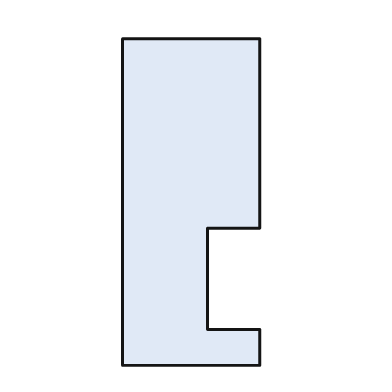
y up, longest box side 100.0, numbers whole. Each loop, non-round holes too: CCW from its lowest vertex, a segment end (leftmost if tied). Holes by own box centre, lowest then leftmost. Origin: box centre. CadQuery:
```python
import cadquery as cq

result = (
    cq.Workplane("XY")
    .moveTo(-21.0, -50.0)
    .lineTo(21.0, -50.0)
    .lineTo(21.0, -39.0)
    .lineTo(5.0, -39.0)
    .lineTo(5.0, -8.0)
    .lineTo(21.0, -8.0)
    .lineTo(21.0, 50.0)
    .lineTo(-21.0, 50.0)
    .close()
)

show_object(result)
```